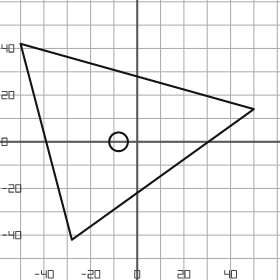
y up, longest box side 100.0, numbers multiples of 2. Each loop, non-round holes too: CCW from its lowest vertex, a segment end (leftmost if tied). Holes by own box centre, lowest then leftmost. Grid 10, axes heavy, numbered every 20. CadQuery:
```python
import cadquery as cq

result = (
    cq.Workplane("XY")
    .moveTo(-28.0, -42.0)
    .lineTo(50.0, 14.0)
    .lineTo(-50.0, 42.0)
    .close()
    .moveTo(-8.0, 0.0)
    .circle(4.0)
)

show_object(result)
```